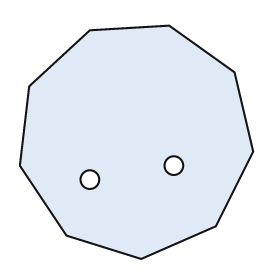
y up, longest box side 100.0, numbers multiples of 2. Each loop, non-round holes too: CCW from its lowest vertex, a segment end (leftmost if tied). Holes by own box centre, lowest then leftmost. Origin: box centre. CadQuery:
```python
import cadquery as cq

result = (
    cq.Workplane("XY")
    .moveTo(2.0, -50.0)
    .lineTo(34.0, -36.0)
    .lineTo(50.0, -4.0)
    .lineTo(42.0, 30.0)
    .lineTo(14.0, 50.0)
    .lineTo(-20.0, 48.0)
    .lineTo(-46.0, 24.0)
    .lineTo(-50.0, -10.0)
    .lineTo(-30.0, -40.0)
    .close()
    .moveTo(-20.0, -16.0)
    .circle(4.0)
    .moveTo(16.0, -10.0)
    .circle(4.0)
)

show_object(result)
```